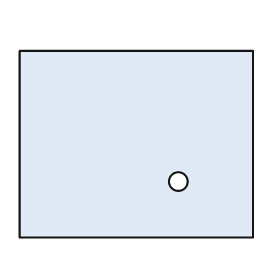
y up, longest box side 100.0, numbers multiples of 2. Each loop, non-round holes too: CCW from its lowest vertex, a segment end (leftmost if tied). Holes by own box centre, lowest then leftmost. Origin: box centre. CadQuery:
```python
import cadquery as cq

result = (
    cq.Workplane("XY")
    .moveTo(-50.0, -40.0)
    .lineTo(50.0, -40.0)
    .lineTo(50.0, 40.0)
    .lineTo(-50.0, 40.0)
    .close()
    .moveTo(18.0, -16.0)
    .circle(4.0)
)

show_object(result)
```